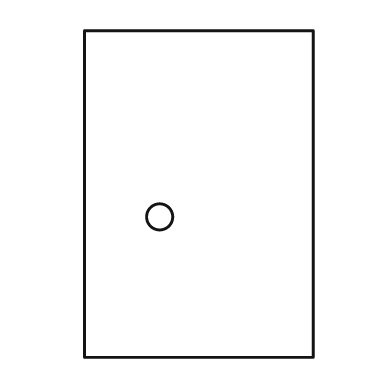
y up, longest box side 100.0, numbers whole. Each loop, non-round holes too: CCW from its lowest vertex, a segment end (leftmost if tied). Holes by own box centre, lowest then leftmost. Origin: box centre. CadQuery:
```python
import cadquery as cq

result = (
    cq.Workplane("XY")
    .moveTo(-35.0, -50.0)
    .lineTo(35.0, -50.0)
    .lineTo(35.0, 50.0)
    .lineTo(-35.0, 50.0)
    .close()
    .moveTo(-12.0, -7.0)
    .circle(4.0)
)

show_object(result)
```